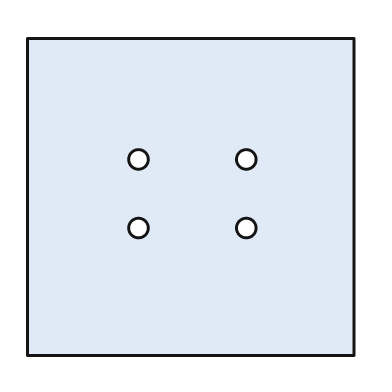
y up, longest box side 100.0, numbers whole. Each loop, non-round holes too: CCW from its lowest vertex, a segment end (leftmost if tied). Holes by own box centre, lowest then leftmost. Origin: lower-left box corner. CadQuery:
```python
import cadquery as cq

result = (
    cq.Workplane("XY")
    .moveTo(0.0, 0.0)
    .lineTo(100.0, 0.0)
    .lineTo(100.0, 97.0)
    .lineTo(0.0, 97.0)
    .close()
    .moveTo(34.0, 39.0)
    .circle(3.0)
    .moveTo(67.0, 39.0)
    .circle(3.0)
    .moveTo(34.0, 60.0)
    .circle(3.0)
    .moveTo(67.0, 60.0)
    .circle(3.0)
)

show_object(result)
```